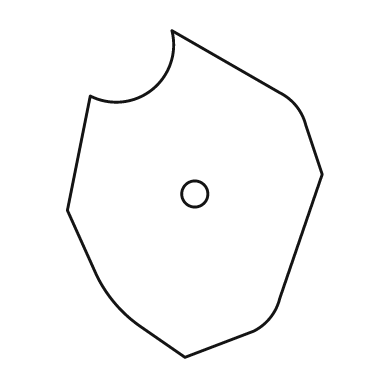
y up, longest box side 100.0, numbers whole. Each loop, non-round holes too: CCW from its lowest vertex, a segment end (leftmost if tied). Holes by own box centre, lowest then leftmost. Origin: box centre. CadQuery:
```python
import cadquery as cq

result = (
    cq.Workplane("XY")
    .moveTo(-3.0, -50.0)
    .lineTo(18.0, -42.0)
    .threePointArc((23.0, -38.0), (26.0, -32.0))
    .lineTo(39.0, 6.0)
    .lineTo(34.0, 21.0)
    .threePointArc((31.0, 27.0), (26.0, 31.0))
    .lineTo(-7.0, 50.0)
    .threePointArc((-13.0, 32.0), (-32.0, 30.0))
    .lineTo(-39.0, -5.0)
    .lineTo(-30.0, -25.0)
    .threePointArc((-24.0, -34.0), (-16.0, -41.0))
    .close()
    .moveTo(0.0, 0.0)
    .circle(4.0)
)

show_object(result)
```